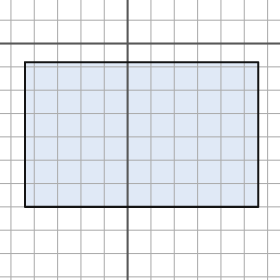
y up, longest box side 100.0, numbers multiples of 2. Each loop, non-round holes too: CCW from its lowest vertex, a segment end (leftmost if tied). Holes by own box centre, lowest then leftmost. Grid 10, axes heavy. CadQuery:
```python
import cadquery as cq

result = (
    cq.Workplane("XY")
    .moveTo(-44.0, -70.0)
    .lineTo(56.0, -70.0)
    .lineTo(56.0, -8.0)
    .lineTo(-44.0, -8.0)
    .close()
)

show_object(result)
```